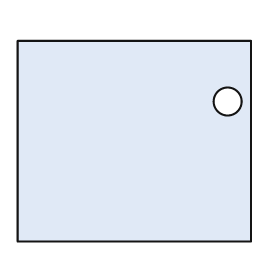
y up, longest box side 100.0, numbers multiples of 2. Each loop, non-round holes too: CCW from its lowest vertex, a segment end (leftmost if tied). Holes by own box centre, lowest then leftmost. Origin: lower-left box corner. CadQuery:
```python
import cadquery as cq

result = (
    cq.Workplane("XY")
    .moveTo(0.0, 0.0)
    .lineTo(100.0, 0.0)
    .lineTo(100.0, 86.0)
    .lineTo(0.0, 86.0)
    .close()
    .moveTo(90.0, 60.0)
    .circle(6.0)
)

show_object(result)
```